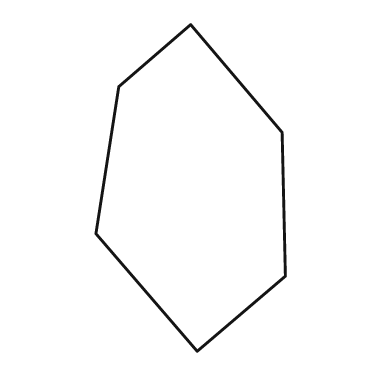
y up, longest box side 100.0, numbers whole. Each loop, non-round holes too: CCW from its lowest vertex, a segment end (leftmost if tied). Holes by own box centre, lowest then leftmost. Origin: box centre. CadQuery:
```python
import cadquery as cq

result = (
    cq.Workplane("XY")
    .moveTo(2.0, -50.0)
    .lineTo(29.0, -27.0)
    .lineTo(28.0, 17.0)
    .lineTo(0.0, 50.0)
    .lineTo(-22.0, 31.0)
    .lineTo(-29.0, -14.0)
    .close()
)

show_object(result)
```